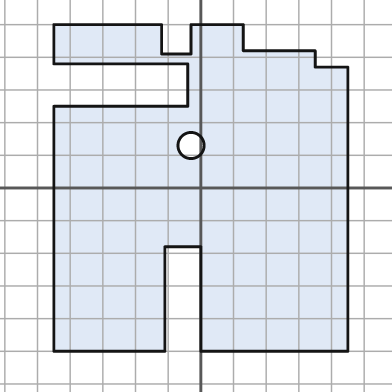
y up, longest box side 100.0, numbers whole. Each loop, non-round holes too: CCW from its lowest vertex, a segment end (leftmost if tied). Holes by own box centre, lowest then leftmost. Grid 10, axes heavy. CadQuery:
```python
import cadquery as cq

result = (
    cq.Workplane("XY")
    .moveTo(-45.0, -50.0)
    .lineTo(-11.0, -50.0)
    .lineTo(-11.0, -18.0)
    .lineTo(0.0, -18.0)
    .lineTo(0.0, -50.0)
    .lineTo(45.0, -50.0)
    .lineTo(45.0, 37.0)
    .lineTo(35.0, 37.0)
    .lineTo(35.0, 42.0)
    .lineTo(13.0, 42.0)
    .lineTo(13.0, 50.0)
    .lineTo(-3.0, 50.0)
    .lineTo(-3.0, 41.0)
    .lineTo(-12.0, 41.0)
    .lineTo(-12.0, 50.0)
    .lineTo(-45.0, 50.0)
    .lineTo(-45.0, 38.0)
    .lineTo(-4.0, 38.0)
    .lineTo(-4.0, 25.0)
    .lineTo(-45.0, 25.0)
    .close()
    .moveTo(-3.0, 13.0)
    .circle(4.0)
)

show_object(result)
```